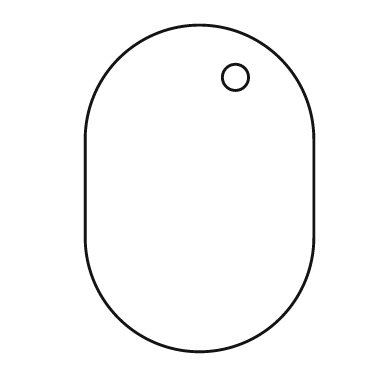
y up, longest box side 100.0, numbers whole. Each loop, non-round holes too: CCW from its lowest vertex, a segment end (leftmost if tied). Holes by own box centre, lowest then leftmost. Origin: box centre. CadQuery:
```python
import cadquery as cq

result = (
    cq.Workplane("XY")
    .moveTo(-35.0, -15.0)
    .threePointArc((0.0, -50.0), (35.0, -15.0))
    .lineTo(35.0, 15.0)
    .threePointArc((0.0, 50.0), (-35.0, 15.0))
    .close()
    .moveTo(11.0, 34.0)
    .circle(4.0)
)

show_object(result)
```